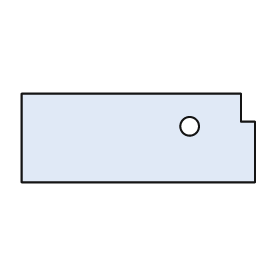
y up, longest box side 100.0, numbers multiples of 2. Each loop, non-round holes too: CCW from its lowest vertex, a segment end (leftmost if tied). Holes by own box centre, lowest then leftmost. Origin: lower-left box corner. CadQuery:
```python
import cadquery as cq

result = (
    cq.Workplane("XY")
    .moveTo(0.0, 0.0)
    .lineTo(100.0, 0.0)
    .lineTo(100.0, 26.0)
    .lineTo(94.0, 26.0)
    .lineTo(94.0, 38.0)
    .lineTo(0.0, 38.0)
    .close()
    .moveTo(72.0, 24.0)
    .circle(4.0)
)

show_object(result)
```